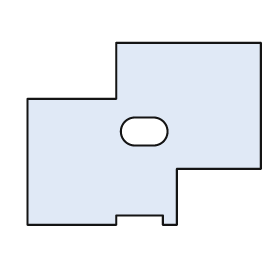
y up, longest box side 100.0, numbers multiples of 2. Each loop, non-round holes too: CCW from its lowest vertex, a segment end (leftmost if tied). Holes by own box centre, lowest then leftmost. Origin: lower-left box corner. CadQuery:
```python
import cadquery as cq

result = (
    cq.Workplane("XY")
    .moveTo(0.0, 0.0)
    .lineTo(38.0, 0.0)
    .lineTo(38.0, 4.0)
    .lineTo(58.0, 4.0)
    .lineTo(58.0, 0.0)
    .lineTo(64.0, 0.0)
    .lineTo(64.0, 24.0)
    .lineTo(100.0, 24.0)
    .lineTo(100.0, 78.0)
    .lineTo(38.0, 78.0)
    .lineTo(38.0, 54.0)
    .lineTo(0.0, 54.0)
    .close()
    .moveTo(46.0, 34.0)
    .lineTo(54.0, 34.0)
    .threePointArc((60.0, 40.0), (54.0, 46.0))
    .lineTo(46.0, 46.0)
    .threePointArc((40.0, 40.0), (46.0, 34.0))
    .close()
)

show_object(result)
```